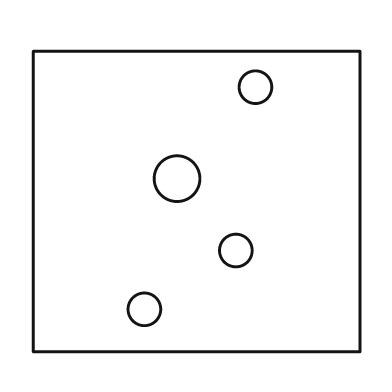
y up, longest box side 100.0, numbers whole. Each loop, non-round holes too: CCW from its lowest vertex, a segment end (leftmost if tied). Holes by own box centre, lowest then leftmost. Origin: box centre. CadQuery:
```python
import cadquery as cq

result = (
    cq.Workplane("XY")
    .moveTo(-50.0, -46.0)
    .lineTo(50.0, -46.0)
    .lineTo(50.0, 46.0)
    .lineTo(-50.0, 46.0)
    .close()
    .moveTo(-16.0, -33.0)
    .circle(5.0)
    .moveTo(12.0, -15.0)
    .circle(5.0)
    .moveTo(-6.0, 7.0)
    .circle(7.0)
    .moveTo(18.0, 35.0)
    .circle(5.0)
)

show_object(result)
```